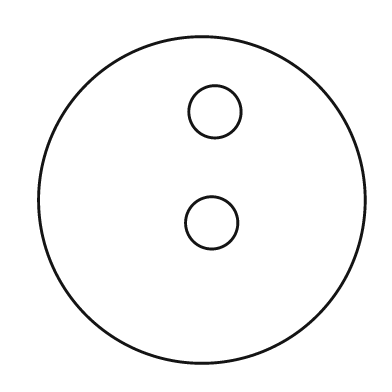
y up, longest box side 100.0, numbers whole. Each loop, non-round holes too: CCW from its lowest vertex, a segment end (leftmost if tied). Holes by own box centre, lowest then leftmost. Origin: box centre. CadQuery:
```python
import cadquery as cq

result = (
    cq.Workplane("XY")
    .moveTo(0.0, 0.0)
    .circle(50.0)
    .moveTo(3.0, -7.0)
    .circle(8.0)
    .moveTo(4.0, 27.0)
    .circle(8.0)
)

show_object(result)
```